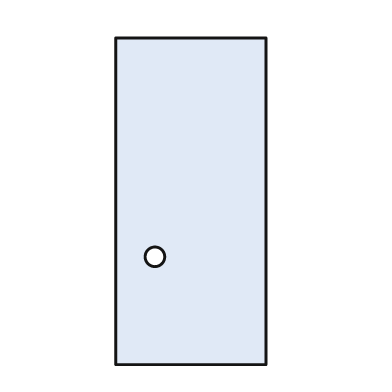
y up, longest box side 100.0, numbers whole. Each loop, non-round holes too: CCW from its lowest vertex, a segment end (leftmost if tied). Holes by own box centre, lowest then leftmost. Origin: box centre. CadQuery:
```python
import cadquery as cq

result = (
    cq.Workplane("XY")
    .moveTo(-23.0, -50.0)
    .lineTo(23.0, -50.0)
    .lineTo(23.0, 50.0)
    .lineTo(-23.0, 50.0)
    .close()
    .moveTo(-11.0, -17.0)
    .circle(3.0)
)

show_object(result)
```